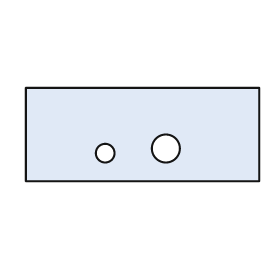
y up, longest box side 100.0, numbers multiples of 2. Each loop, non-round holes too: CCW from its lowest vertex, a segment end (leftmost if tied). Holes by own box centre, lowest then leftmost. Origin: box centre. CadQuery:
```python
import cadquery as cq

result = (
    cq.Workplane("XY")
    .moveTo(-50.0, -20.0)
    .lineTo(50.0, -20.0)
    .lineTo(50.0, 20.0)
    .lineTo(-50.0, 20.0)
    .close()
    .moveTo(-16.0, -8.0)
    .circle(4.0)
    .moveTo(10.0, -6.0)
    .circle(6.0)
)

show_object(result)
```